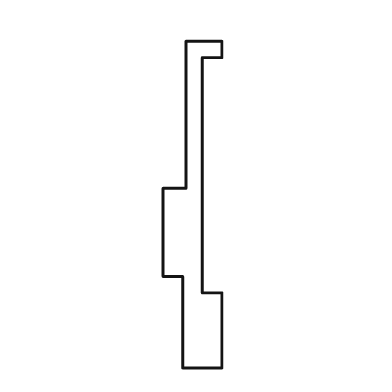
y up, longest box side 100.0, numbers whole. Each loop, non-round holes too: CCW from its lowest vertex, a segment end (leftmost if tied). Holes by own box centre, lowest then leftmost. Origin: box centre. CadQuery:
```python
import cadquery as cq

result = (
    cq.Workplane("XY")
    .moveTo(-3.0, -50.0)
    .lineTo(9.0, -50.0)
    .lineTo(9.0, -27.0)
    .lineTo(3.0, -27.0)
    .lineTo(3.0, 45.0)
    .lineTo(9.0, 45.0)
    .lineTo(9.0, 50.0)
    .lineTo(-2.0, 50.0)
    .lineTo(-2.0, 5.0)
    .lineTo(-9.0, 5.0)
    .lineTo(-9.0, -22.0)
    .lineTo(-3.0, -22.0)
    .close()
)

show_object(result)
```